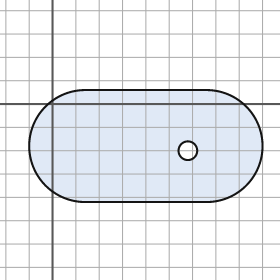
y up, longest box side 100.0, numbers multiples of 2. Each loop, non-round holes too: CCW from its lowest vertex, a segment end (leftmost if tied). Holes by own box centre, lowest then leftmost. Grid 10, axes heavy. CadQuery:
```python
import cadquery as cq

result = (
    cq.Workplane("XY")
    .moveTo(14.0, -42.0)
    .lineTo(66.0, -42.0)
    .threePointArc((90.0, -18.0), (66.0, 6.0))
    .lineTo(14.0, 6.0)
    .threePointArc((-10.0, -18.0), (14.0, -42.0))
    .close()
    .moveTo(58.0, -20.0)
    .circle(4.0)
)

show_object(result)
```